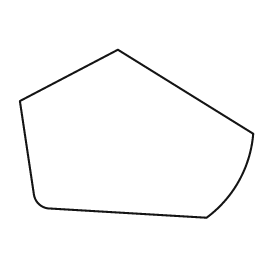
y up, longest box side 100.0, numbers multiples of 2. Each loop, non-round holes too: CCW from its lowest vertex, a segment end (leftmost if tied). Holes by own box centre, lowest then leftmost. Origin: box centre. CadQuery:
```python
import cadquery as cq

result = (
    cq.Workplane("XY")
    .moveTo(30.0, -36.0)
    .threePointArc((44.0, -20.0), (50.0, 0.0))
    .lineTo(-8.0, 36.0)
    .lineTo(-50.0, 14.0)
    .lineTo(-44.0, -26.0)
    .threePointArc((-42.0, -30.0), (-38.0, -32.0))
    .close()
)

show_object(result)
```